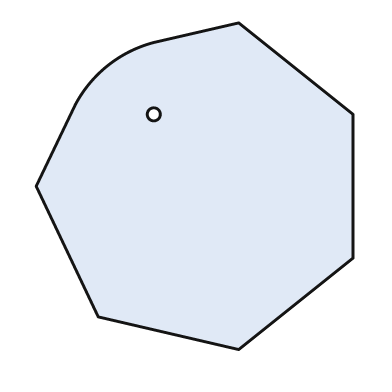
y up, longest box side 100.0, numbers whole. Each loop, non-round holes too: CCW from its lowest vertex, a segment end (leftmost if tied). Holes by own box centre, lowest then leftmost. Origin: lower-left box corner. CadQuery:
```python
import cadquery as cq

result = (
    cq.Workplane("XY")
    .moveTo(62.0, 0.0)
    .lineTo(97.0, 28.0)
    .lineTo(97.0, 72.0)
    .lineTo(62.0, 100.0)
    .lineTo(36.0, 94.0)
    .threePointArc((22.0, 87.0), (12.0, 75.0))
    .lineTo(0.0, 50.0)
    .lineTo(19.0, 10.0)
    .close()
    .moveTo(36.0, 72.0)
    .circle(2.0)
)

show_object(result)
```